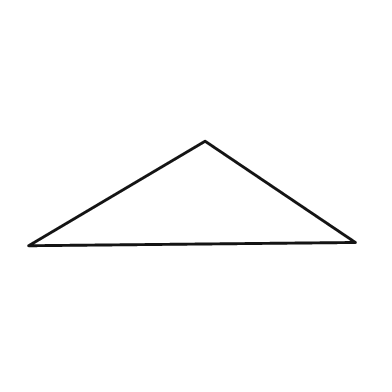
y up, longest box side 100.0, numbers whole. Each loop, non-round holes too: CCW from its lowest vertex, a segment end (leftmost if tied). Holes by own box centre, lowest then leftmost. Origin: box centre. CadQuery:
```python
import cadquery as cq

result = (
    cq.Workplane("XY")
    .moveTo(-50.0, -16.0)
    .lineTo(50.0, -15.0)
    .lineTo(4.0, 16.0)
    .close()
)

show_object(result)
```